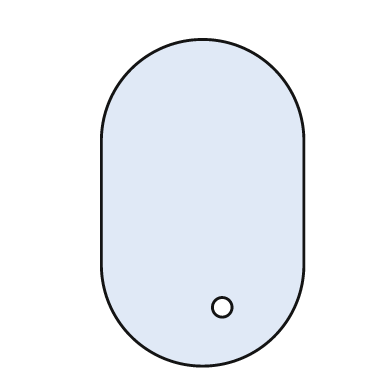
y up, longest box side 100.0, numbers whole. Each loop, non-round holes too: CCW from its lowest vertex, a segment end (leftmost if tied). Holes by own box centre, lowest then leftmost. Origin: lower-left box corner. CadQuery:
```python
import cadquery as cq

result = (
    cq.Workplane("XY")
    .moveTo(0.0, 31.0)
    .threePointArc((31.0, 0.0), (62.0, 31.0))
    .lineTo(62.0, 69.0)
    .threePointArc((31.0, 100.0), (0.0, 69.0))
    .close()
    .moveTo(37.0, 18.0)
    .circle(3.0)
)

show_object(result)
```